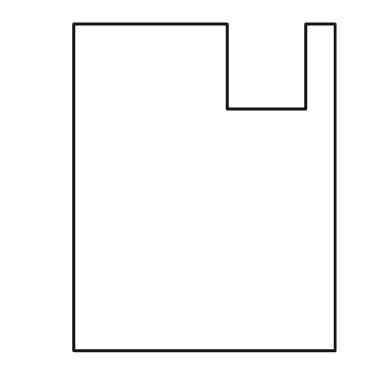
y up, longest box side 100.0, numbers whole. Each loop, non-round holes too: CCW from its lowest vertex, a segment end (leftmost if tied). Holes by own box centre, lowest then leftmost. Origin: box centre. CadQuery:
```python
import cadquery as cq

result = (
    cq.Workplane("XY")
    .moveTo(-40.0, -50.0)
    .lineTo(40.0, -50.0)
    .lineTo(40.0, 50.0)
    .lineTo(31.0, 50.0)
    .lineTo(31.0, 24.0)
    .lineTo(7.0, 24.0)
    .lineTo(7.0, 50.0)
    .lineTo(-40.0, 50.0)
    .close()
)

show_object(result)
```